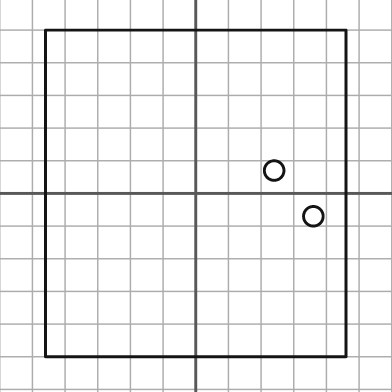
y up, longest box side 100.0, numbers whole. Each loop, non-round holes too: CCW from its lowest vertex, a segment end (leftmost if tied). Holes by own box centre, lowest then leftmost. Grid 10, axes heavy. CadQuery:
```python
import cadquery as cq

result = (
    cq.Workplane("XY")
    .moveTo(-46.0, -50.0)
    .lineTo(46.0, -50.0)
    .lineTo(46.0, 50.0)
    .lineTo(-46.0, 50.0)
    .close()
    .moveTo(36.0, -7.0)
    .circle(3.0)
    .moveTo(24.0, 7.0)
    .circle(3.0)
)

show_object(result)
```